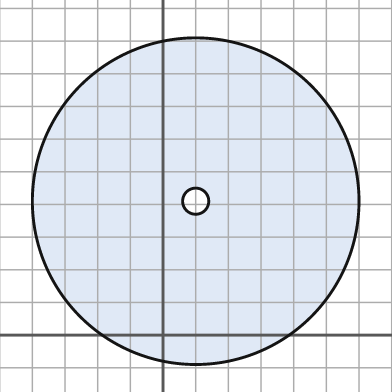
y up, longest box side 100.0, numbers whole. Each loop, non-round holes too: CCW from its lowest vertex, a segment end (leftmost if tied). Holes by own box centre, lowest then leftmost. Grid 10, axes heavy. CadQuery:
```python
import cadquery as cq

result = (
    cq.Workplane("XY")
    .moveTo(10.0, 41.0)
    .circle(50.0)
    .moveTo(10.0, 41.0)
    .circle(4.0)
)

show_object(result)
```